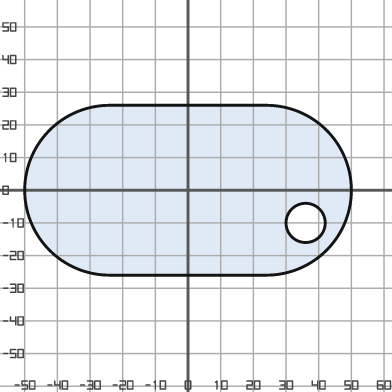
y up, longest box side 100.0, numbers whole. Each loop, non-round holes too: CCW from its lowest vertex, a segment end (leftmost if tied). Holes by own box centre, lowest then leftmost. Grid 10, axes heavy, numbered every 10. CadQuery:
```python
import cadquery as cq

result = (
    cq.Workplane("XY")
    .moveTo(-24.0, -26.0)
    .lineTo(24.0, -26.0)
    .threePointArc((50.0, 0.0), (24.0, 26.0))
    .lineTo(-24.0, 26.0)
    .threePointArc((-50.0, 0.0), (-24.0, -26.0))
    .close()
    .moveTo(36.0, -10.0)
    .circle(6.0)
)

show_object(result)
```